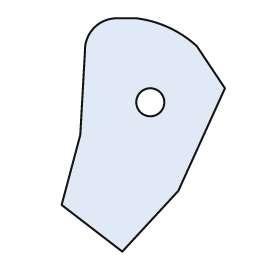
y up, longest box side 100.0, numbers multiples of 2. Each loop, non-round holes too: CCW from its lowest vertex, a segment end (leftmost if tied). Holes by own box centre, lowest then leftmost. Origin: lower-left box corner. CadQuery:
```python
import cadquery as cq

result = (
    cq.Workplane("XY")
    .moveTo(26.0, 0.0)
    .lineTo(50.0, 26.0)
    .lineTo(70.0, 70.0)
    .lineTo(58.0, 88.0)
    .threePointArc((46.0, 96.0), (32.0, 100.0))
    .lineTo(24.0, 100.0)
    .threePointArc((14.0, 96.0), (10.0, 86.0))
    .lineTo(8.0, 50.0)
    .lineTo(0.0, 20.0)
    .close()
    .moveTo(38.0, 64.0)
    .circle(6.0)
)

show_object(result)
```